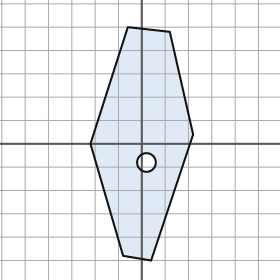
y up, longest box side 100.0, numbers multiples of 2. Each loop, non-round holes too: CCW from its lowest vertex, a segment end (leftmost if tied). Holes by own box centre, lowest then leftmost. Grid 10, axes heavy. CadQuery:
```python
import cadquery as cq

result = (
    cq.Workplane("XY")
    .moveTo(4.0, -50.0)
    .lineTo(22.0, 4.0)
    .lineTo(12.0, 48.0)
    .lineTo(-6.0, 50.0)
    .lineTo(-22.0, 0.0)
    .lineTo(-8.0, -48.0)
    .close()
    .moveTo(2.0, -8.0)
    .circle(4.0)
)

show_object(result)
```